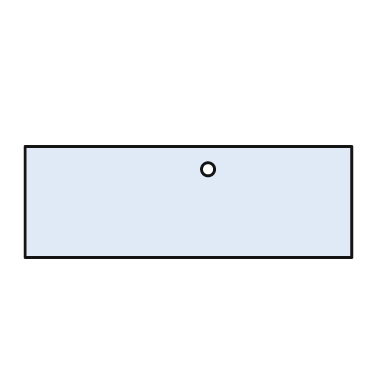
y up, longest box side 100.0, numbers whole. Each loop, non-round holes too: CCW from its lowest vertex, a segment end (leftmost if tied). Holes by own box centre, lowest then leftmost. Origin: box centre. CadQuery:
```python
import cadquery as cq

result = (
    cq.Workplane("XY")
    .moveTo(-50.0, -17.0)
    .lineTo(50.0, -17.0)
    .lineTo(50.0, 17.0)
    .lineTo(-50.0, 17.0)
    .close()
    .moveTo(6.0, 10.0)
    .circle(2.0)
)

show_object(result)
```